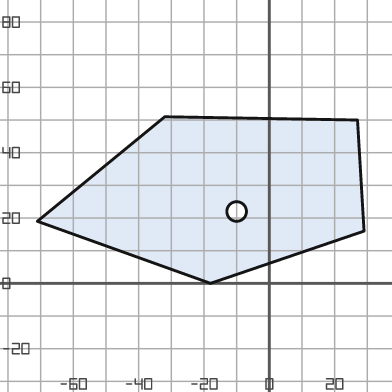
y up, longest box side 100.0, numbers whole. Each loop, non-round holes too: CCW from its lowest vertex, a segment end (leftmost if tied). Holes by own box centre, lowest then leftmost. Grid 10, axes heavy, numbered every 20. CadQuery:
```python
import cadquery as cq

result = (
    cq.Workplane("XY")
    .moveTo(-18.0, 0.0)
    .lineTo(29.0, 16.0)
    .lineTo(27.0, 50.0)
    .lineTo(-32.0, 51.0)
    .lineTo(-71.0, 19.0)
    .close()
    .moveTo(-10.0, 22.0)
    .circle(3.0)
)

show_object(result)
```